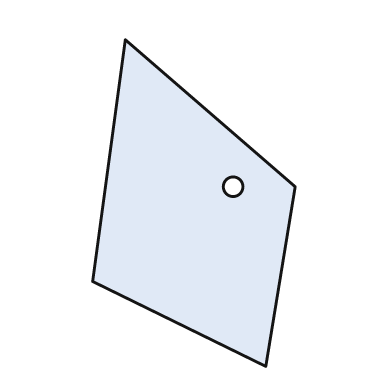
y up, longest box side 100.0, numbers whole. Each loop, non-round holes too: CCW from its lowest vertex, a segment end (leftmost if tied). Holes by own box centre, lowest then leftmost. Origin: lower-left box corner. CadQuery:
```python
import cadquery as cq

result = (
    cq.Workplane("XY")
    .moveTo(53.0, 0.0)
    .lineTo(62.0, 55.0)
    .lineTo(10.0, 100.0)
    .lineTo(0.0, 26.0)
    .close()
    .moveTo(43.0, 55.0)
    .circle(3.0)
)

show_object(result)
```